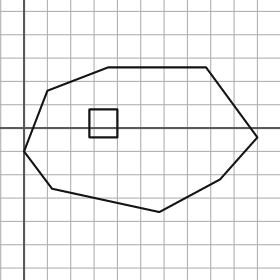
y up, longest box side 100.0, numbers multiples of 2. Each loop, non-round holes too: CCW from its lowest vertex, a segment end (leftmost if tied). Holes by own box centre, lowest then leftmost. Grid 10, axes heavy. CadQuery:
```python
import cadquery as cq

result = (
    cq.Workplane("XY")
    .moveTo(58.0, -36.0)
    .lineTo(84.0, -22.0)
    .lineTo(100.0, -4.0)
    .lineTo(78.0, 26.0)
    .lineTo(36.0, 26.0)
    .lineTo(10.0, 16.0)
    .lineTo(0.0, -10.0)
    .lineTo(12.0, -26.0)
    .close()
    .moveTo(28.0, -4.0)
    .lineTo(40.0, -4.0)
    .lineTo(40.0, 8.0)
    .lineTo(28.0, 8.0)
    .close()
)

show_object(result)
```